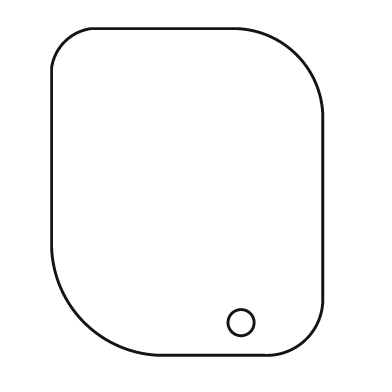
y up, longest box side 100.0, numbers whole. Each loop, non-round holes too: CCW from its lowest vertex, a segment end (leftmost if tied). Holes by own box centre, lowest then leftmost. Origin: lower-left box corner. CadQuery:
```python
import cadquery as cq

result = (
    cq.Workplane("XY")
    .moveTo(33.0, 0.0)
    .lineTo(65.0, 0.0)
    .threePointArc((78.0, 5.0), (83.0, 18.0))
    .lineTo(83.0, 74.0)
    .threePointArc((75.0, 92.0), (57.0, 100.0))
    .lineTo(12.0, 100.0)
    .threePointArc((4.0, 96.0), (0.0, 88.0))
    .lineTo(0.0, 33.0)
    .threePointArc((10.0, 10.0), (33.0, 0.0))
    .close()
    .moveTo(58.0, 10.0)
    .circle(4.0)
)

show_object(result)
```